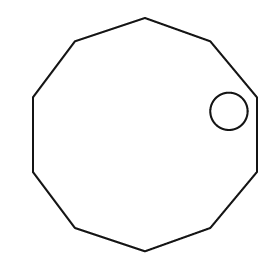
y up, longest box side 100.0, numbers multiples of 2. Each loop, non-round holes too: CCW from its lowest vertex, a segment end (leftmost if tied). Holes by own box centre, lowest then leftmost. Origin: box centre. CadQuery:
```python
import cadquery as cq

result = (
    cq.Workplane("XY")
    .moveTo(0.0, -50.0)
    .lineTo(28.0, -40.0)
    .lineTo(48.0, -16.0)
    .lineTo(48.0, 16.0)
    .lineTo(28.0, 40.0)
    .lineTo(0.0, 50.0)
    .lineTo(-30.0, 40.0)
    .lineTo(-48.0, 16.0)
    .lineTo(-48.0, -16.0)
    .lineTo(-30.0, -40.0)
    .close()
    .moveTo(36.0, 10.0)
    .circle(8.0)
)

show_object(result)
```